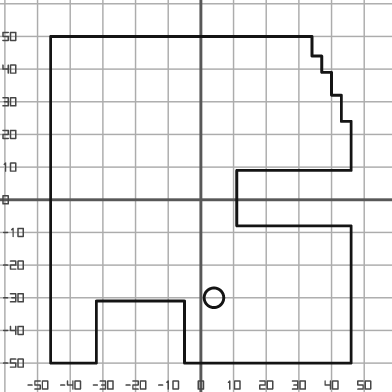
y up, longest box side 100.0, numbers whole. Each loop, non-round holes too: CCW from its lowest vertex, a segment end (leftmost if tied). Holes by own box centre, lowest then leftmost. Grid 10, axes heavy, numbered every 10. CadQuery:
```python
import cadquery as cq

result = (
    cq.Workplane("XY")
    .moveTo(-46.0, -50.0)
    .lineTo(-32.0, -50.0)
    .lineTo(-32.0, -31.0)
    .lineTo(-5.0, -31.0)
    .lineTo(-5.0, -50.0)
    .lineTo(46.0, -50.0)
    .lineTo(46.0, -8.0)
    .lineTo(11.0, -8.0)
    .lineTo(11.0, 9.0)
    .lineTo(46.0, 9.0)
    .lineTo(46.0, 24.0)
    .lineTo(43.0, 24.0)
    .lineTo(43.0, 32.0)
    .lineTo(40.0, 32.0)
    .lineTo(40.0, 39.0)
    .lineTo(37.0, 39.0)
    .lineTo(37.0, 44.0)
    .lineTo(34.0, 44.0)
    .lineTo(34.0, 50.0)
    .lineTo(-46.0, 50.0)
    .close()
    .moveTo(4.0, -30.0)
    .circle(3.0)
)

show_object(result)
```